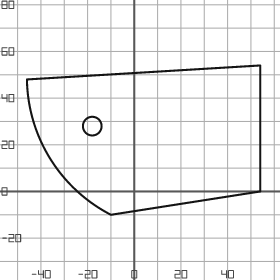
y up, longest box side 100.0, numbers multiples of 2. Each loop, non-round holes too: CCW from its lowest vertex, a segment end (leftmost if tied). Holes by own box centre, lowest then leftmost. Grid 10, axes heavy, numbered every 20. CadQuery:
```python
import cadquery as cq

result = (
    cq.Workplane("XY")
    .moveTo(-10.0, -10.0)
    .lineTo(54.0, 0.0)
    .lineTo(54.0, 54.0)
    .lineTo(-46.0, 48.0)
    .threePointArc((-36.0, 14.0), (-10.0, -10.0))
    .close()
    .moveTo(-18.0, 28.0)
    .circle(4.0)
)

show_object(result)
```